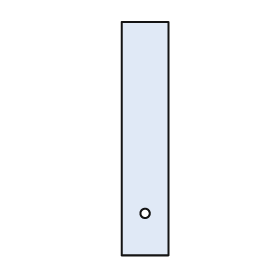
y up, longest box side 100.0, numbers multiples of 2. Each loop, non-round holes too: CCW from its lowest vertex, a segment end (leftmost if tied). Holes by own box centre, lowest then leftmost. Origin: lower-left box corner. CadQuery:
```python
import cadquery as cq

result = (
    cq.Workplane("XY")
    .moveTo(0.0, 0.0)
    .lineTo(20.0, 0.0)
    .lineTo(20.0, 100.0)
    .lineTo(0.0, 100.0)
    .close()
    .moveTo(10.0, 18.0)
    .circle(2.0)
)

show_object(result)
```